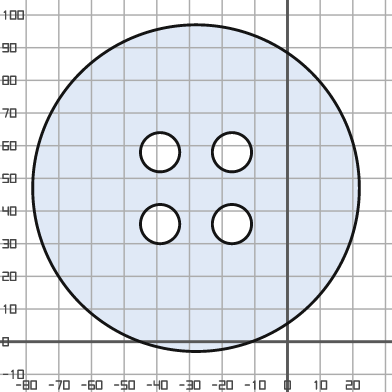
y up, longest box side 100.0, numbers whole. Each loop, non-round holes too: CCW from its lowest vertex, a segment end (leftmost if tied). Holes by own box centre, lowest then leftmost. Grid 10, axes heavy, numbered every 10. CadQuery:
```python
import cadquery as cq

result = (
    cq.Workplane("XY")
    .moveTo(-28.0, 47.0)
    .circle(50.0)
    .moveTo(-39.0, 36.0)
    .circle(6.0)
    .moveTo(-17.0, 36.0)
    .circle(6.0)
    .moveTo(-39.0, 58.0)
    .circle(6.0)
    .moveTo(-17.0, 58.0)
    .circle(6.0)
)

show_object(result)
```